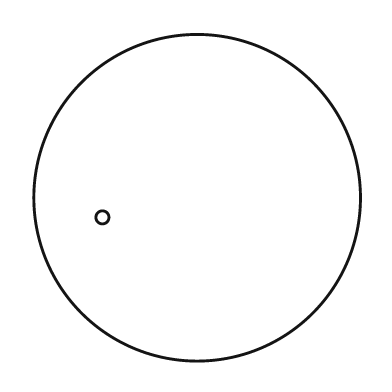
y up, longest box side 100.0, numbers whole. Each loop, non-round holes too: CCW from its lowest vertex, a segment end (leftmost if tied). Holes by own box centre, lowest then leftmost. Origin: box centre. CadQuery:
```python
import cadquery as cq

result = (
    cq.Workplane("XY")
    .moveTo(0.0, 0.0)
    .circle(50.0)
    .moveTo(-29.0, -6.0)
    .circle(2.0)
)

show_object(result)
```